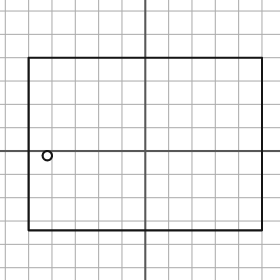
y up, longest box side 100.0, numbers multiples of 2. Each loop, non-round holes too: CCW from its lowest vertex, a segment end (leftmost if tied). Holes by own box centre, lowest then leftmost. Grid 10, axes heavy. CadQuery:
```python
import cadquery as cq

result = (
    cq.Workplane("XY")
    .moveTo(-50.0, -34.0)
    .lineTo(50.0, -34.0)
    .lineTo(50.0, 40.0)
    .lineTo(-50.0, 40.0)
    .close()
    .moveTo(-42.0, -2.0)
    .circle(2.0)
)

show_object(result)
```